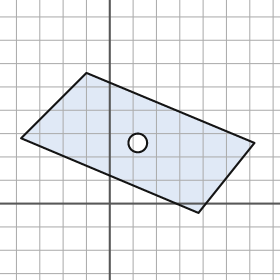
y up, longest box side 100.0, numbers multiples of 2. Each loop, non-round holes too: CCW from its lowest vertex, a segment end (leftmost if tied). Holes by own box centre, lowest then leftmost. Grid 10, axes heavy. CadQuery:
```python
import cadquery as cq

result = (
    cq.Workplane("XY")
    .moveTo(38.0, -4.0)
    .lineTo(62.0, 26.0)
    .lineTo(-10.0, 56.0)
    .lineTo(-38.0, 28.0)
    .close()
    .moveTo(12.0, 26.0)
    .circle(4.0)
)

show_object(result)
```